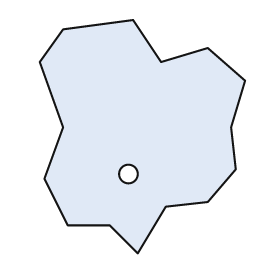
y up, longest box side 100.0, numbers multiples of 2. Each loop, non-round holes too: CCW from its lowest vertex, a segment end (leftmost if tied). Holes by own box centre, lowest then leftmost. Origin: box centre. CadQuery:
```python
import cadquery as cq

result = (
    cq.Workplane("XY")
    .moveTo(-2.0, -50.0)
    .lineTo(10.0, -30.0)
    .lineTo(28.0, -28.0)
    .lineTo(40.0, -14.0)
    .lineTo(38.0, 4.0)
    .lineTo(44.0, 24.0)
    .lineTo(28.0, 38.0)
    .lineTo(8.0, 32.0)
    .lineTo(-4.0, 50.0)
    .lineTo(-34.0, 46.0)
    .lineTo(-44.0, 32.0)
    .lineTo(-34.0, 4.0)
    .lineTo(-42.0, -18.0)
    .lineTo(-32.0, -38.0)
    .lineTo(-14.0, -38.0)
    .close()
    .moveTo(-6.0, -16.0)
    .circle(4.0)
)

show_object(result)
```